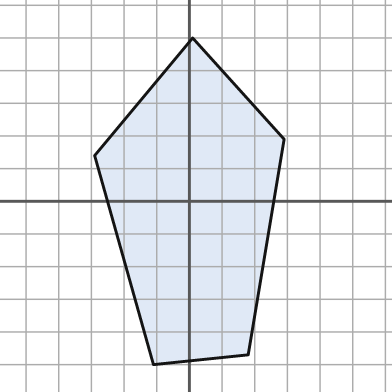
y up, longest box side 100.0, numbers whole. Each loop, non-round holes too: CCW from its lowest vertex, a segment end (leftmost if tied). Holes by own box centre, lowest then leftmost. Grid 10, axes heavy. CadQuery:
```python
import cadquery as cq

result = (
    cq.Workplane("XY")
    .moveTo(-11.0, -50.0)
    .lineTo(18.0, -47.0)
    .lineTo(29.0, 19.0)
    .lineTo(1.0, 50.0)
    .lineTo(-29.0, 14.0)
    .close()
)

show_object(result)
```